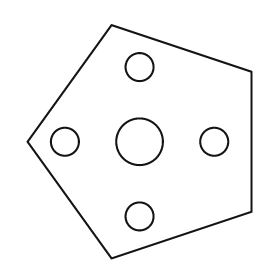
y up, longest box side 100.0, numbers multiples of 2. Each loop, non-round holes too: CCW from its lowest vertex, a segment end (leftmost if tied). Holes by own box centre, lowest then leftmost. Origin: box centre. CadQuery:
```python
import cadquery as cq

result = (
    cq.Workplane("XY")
    .moveTo(-12.0, -50.0)
    .lineTo(48.0, -30.0)
    .lineTo(48.0, 30.0)
    .lineTo(-12.0, 50.0)
    .lineTo(-48.0, 0.0)
    .close()
    .moveTo(0.0, -32.0)
    .circle(6.0)
    .moveTo(-32.0, 0.0)
    .circle(6.0)
    .moveTo(0.0, 0.0)
    .circle(10.0)
    .moveTo(32.0, 0.0)
    .circle(6.0)
    .moveTo(0.0, 32.0)
    .circle(6.0)
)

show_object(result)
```